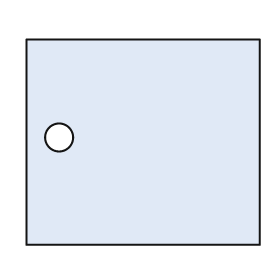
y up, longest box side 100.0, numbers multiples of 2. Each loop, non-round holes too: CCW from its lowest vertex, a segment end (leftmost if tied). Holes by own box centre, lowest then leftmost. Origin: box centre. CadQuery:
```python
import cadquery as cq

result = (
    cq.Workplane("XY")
    .moveTo(-50.0, -44.0)
    .lineTo(50.0, -44.0)
    .lineTo(50.0, 44.0)
    .lineTo(-50.0, 44.0)
    .close()
    .moveTo(-36.0, 2.0)
    .circle(6.0)
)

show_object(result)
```